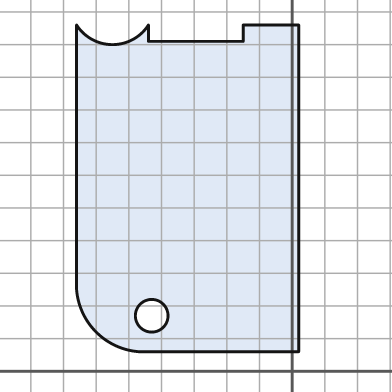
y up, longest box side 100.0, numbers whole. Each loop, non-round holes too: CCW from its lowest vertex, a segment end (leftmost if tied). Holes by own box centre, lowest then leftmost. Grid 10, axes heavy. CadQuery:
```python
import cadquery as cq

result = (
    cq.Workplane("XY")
    .moveTo(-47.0, 6.0)
    .lineTo(2.0, 6.0)
    .lineTo(2.0, 106.0)
    .lineTo(-15.0, 106.0)
    .lineTo(-15.0, 101.0)
    .lineTo(-44.0, 101.0)
    .lineTo(-44.0, 106.0)
    .threePointArc((-55.0, 100.0), (-66.0, 106.0))
    .lineTo(-66.0, 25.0)
    .threePointArc((-60.0, 12.0), (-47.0, 6.0))
    .close()
    .moveTo(-43.0, 17.0)
    .circle(5.0)
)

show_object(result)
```